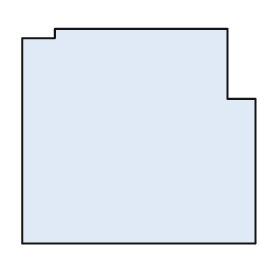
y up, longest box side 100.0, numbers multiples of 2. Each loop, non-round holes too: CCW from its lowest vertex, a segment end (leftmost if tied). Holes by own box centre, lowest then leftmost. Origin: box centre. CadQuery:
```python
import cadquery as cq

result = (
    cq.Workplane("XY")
    .moveTo(-50.0, -46.0)
    .lineTo(50.0, -46.0)
    .lineTo(50.0, 16.0)
    .lineTo(38.0, 16.0)
    .lineTo(38.0, 46.0)
    .lineTo(-36.0, 46.0)
    .lineTo(-36.0, 42.0)
    .lineTo(-50.0, 42.0)
    .close()
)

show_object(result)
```